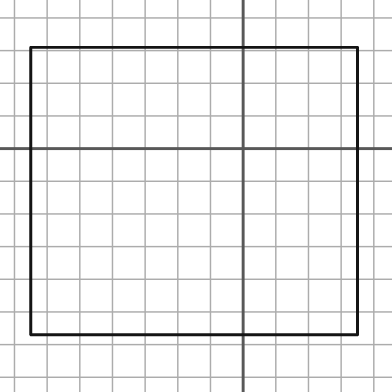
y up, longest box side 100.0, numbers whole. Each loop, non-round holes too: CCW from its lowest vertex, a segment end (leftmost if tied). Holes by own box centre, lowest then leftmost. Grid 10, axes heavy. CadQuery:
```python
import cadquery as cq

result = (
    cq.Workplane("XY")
    .moveTo(-65.0, -57.0)
    .lineTo(35.0, -57.0)
    .lineTo(35.0, 31.0)
    .lineTo(-65.0, 31.0)
    .close()
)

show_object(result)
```